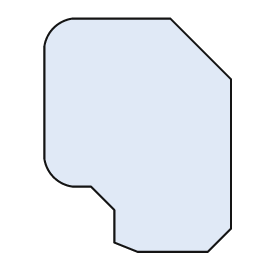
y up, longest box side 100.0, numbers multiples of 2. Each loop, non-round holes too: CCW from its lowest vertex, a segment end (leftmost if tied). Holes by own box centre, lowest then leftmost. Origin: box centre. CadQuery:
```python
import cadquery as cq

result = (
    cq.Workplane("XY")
    .moveTo(0.0, -50.0)
    .lineTo(30.0, -50.0)
    .lineTo(40.0, -40.0)
    .lineTo(40.0, 24.0)
    .lineTo(14.0, 50.0)
    .lineTo(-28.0, 50.0)
    .threePointArc((-36.0, 46.0), (-40.0, 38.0))
    .lineTo(-40.0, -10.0)
    .threePointArc((-36.0, -18.0), (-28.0, -22.0))
    .lineTo(-20.0, -22.0)
    .lineTo(-10.0, -32.0)
    .lineTo(-10.0, -46.0)
    .close()
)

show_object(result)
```